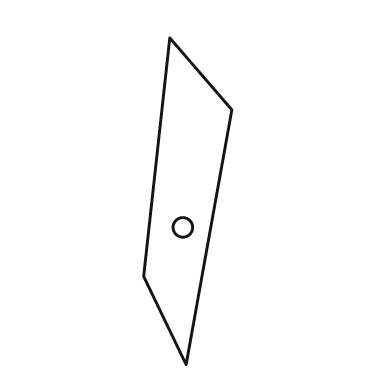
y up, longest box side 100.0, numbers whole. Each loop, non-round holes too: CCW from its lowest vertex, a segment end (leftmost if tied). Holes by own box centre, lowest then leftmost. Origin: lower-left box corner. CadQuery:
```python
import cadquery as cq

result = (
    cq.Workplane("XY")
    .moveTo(13.0, 0.0)
    .lineTo(27.0, 78.0)
    .lineTo(8.0, 100.0)
    .lineTo(0.0, 27.0)
    .close()
    .moveTo(12.0, 42.0)
    .circle(3.0)
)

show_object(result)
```